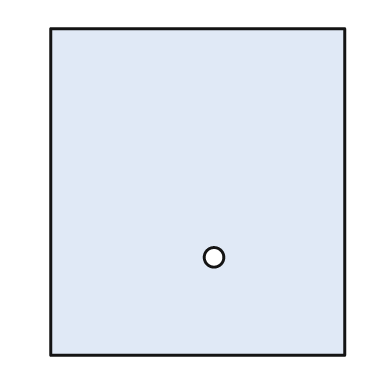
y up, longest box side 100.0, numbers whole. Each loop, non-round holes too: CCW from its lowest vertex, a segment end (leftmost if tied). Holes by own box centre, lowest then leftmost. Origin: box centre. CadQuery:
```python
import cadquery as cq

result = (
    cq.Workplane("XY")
    .moveTo(-45.0, -50.0)
    .lineTo(45.0, -50.0)
    .lineTo(45.0, 50.0)
    .lineTo(-45.0, 50.0)
    .close()
    .moveTo(5.0, -20.0)
    .circle(3.0)
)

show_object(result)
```